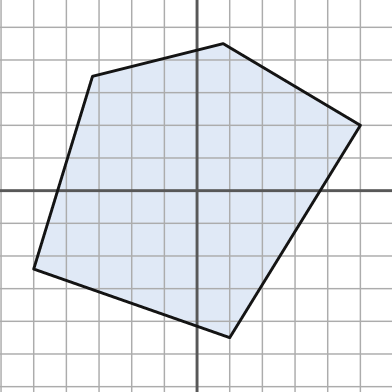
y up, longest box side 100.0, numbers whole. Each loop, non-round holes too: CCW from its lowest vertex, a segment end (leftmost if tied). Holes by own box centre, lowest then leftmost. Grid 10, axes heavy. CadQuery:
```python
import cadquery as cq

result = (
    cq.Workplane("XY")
    .moveTo(10.0, -45.0)
    .lineTo(50.0, 20.0)
    .lineTo(8.0, 45.0)
    .lineTo(-32.0, 35.0)
    .lineTo(-50.0, -24.0)
    .close()
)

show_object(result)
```